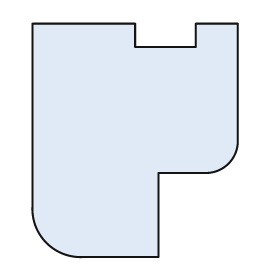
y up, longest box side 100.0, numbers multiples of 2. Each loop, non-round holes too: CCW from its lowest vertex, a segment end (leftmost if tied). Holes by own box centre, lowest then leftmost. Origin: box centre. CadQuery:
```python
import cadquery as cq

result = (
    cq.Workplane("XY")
    .moveTo(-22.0, -50.0)
    .lineTo(10.0, -50.0)
    .lineTo(10.0, -14.0)
    .lineTo(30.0, -14.0)
    .threePointArc((40.0, -10.0), (44.0, 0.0))
    .lineTo(44.0, 50.0)
    .lineTo(26.0, 50.0)
    .lineTo(26.0, 40.0)
    .lineTo(0.0, 40.0)
    .lineTo(0.0, 50.0)
    .lineTo(-44.0, 50.0)
    .lineTo(-44.0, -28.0)
    .threePointArc((-38.0, -44.0), (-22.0, -50.0))
    .close()
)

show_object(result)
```